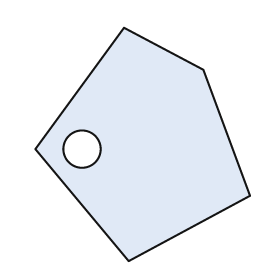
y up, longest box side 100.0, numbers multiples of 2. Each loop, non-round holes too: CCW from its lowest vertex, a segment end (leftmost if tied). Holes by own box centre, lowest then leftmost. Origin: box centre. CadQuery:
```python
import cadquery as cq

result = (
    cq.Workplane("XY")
    .moveTo(-6.0, -50.0)
    .lineTo(46.0, -22.0)
    .lineTo(26.0, 32.0)
    .lineTo(-8.0, 50.0)
    .lineTo(-46.0, -2.0)
    .close()
    .moveTo(-26.0, -2.0)
    .circle(8.0)
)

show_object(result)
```